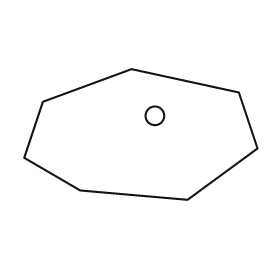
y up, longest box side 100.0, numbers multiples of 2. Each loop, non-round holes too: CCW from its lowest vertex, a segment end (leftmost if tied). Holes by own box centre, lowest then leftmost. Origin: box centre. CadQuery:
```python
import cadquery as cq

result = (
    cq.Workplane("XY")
    .moveTo(20.0, -28.0)
    .lineTo(50.0, -6.0)
    .lineTo(42.0, 18.0)
    .lineTo(-4.0, 28.0)
    .lineTo(-42.0, 14.0)
    .lineTo(-50.0, -10.0)
    .lineTo(-26.0, -24.0)
    .close()
    .moveTo(6.0, 8.0)
    .circle(4.0)
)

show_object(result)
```